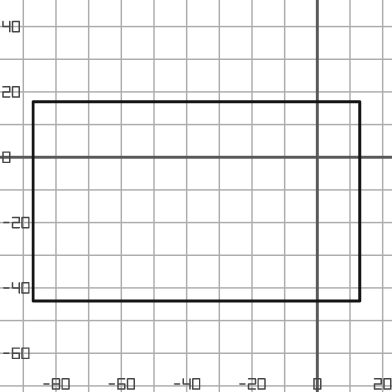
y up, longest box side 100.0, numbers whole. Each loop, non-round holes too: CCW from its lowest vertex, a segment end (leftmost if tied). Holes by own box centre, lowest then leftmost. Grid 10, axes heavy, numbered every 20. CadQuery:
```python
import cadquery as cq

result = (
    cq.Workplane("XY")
    .moveTo(-87.0, -44.0)
    .lineTo(13.0, -44.0)
    .lineTo(13.0, 17.0)
    .lineTo(-87.0, 17.0)
    .close()
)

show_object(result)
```